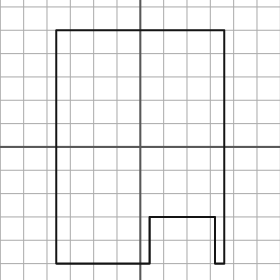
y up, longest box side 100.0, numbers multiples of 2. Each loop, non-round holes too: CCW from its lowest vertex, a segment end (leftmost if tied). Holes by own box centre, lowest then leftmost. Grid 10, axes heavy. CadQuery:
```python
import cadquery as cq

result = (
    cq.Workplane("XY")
    .moveTo(-36.0, -50.0)
    .lineTo(4.0, -50.0)
    .lineTo(4.0, -30.0)
    .lineTo(32.0, -30.0)
    .lineTo(32.0, -50.0)
    .lineTo(36.0, -50.0)
    .lineTo(36.0, 50.0)
    .lineTo(-36.0, 50.0)
    .close()
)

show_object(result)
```